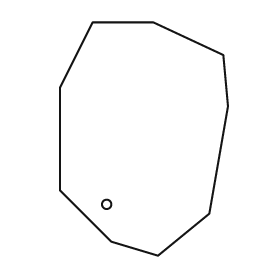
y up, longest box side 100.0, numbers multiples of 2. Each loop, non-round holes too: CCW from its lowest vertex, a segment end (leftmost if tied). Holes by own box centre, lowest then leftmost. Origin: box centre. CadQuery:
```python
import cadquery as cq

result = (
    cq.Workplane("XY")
    .moveTo(6.0, -50.0)
    .lineTo(28.0, -32.0)
    .lineTo(36.0, 14.0)
    .lineTo(34.0, 36.0)
    .lineTo(4.0, 50.0)
    .lineTo(-22.0, 50.0)
    .lineTo(-36.0, 22.0)
    .lineTo(-36.0, -22.0)
    .lineTo(-14.0, -44.0)
    .close()
    .moveTo(-16.0, -28.0)
    .circle(2.0)
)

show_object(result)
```